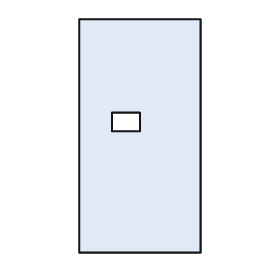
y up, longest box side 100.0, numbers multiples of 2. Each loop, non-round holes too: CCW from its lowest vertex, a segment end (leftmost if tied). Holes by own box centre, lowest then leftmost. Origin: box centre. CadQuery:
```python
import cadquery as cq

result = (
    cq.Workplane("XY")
    .moveTo(-26.0, -50.0)
    .lineTo(26.0, -50.0)
    .lineTo(26.0, 50.0)
    .lineTo(-26.0, 50.0)
    .close()
    .moveTo(-12.0, 2.0)
    .lineTo(0.0, 2.0)
    .lineTo(0.0, 10.0)
    .lineTo(-12.0, 10.0)
    .close()
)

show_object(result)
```